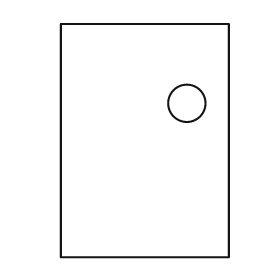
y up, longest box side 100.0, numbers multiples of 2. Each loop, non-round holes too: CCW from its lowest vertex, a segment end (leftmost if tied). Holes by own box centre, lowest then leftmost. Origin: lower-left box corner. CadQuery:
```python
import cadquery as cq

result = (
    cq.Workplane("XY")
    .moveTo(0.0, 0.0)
    .lineTo(72.0, 0.0)
    .lineTo(72.0, 100.0)
    .lineTo(0.0, 100.0)
    .close()
    .moveTo(54.0, 66.0)
    .circle(8.0)
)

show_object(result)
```